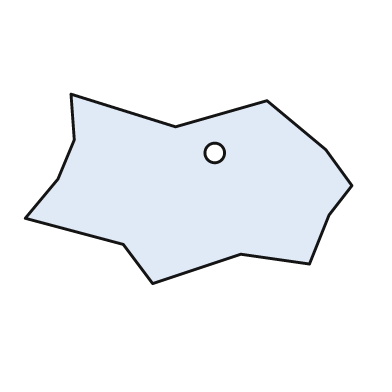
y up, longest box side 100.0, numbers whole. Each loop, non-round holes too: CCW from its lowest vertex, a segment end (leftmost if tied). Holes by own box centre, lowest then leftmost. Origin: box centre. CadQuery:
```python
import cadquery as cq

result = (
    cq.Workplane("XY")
    .moveTo(-11.0, -29.0)
    .lineTo(16.0, -20.0)
    .lineTo(37.0, -23.0)
    .lineTo(43.0, -8.0)
    .lineTo(50.0, 1.0)
    .lineTo(42.0, 12.0)
    .lineTo(24.0, 27.0)
    .lineTo(-4.0, 19.0)
    .lineTo(-36.0, 29.0)
    .lineTo(-35.0, 15.0)
    .lineTo(-40.0, 3.0)
    .lineTo(-50.0, -9.0)
    .lineTo(-20.0, -17.0)
    .close()
    .moveTo(8.0, 11.0)
    .circle(3.0)
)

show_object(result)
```